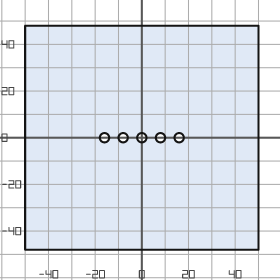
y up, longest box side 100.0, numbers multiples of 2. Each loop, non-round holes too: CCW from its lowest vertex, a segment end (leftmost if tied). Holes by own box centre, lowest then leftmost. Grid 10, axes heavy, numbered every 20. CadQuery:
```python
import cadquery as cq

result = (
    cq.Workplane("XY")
    .moveTo(-50.0, -48.0)
    .lineTo(50.0, -48.0)
    .lineTo(50.0, 48.0)
    .lineTo(-50.0, 48.0)
    .close()
    .moveTo(-16.0, 0.0)
    .circle(2.0)
    .moveTo(-8.0, 0.0)
    .circle(2.0)
    .moveTo(0.0, 0.0)
    .circle(2.0)
    .moveTo(8.0, 0.0)
    .circle(2.0)
    .moveTo(16.0, 0.0)
    .circle(2.0)
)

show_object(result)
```